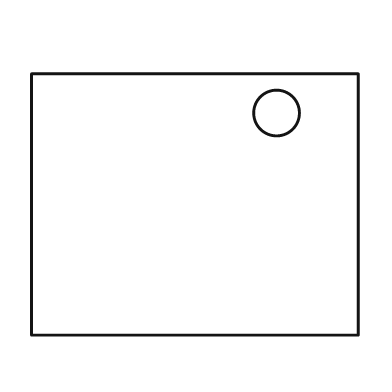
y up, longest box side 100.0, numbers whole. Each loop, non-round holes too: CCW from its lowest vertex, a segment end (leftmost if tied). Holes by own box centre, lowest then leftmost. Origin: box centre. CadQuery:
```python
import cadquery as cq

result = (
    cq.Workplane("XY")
    .moveTo(-50.0, -40.0)
    .lineTo(50.0, -40.0)
    .lineTo(50.0, 40.0)
    .lineTo(-50.0, 40.0)
    .close()
    .moveTo(25.0, 28.0)
    .circle(7.0)
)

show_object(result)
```